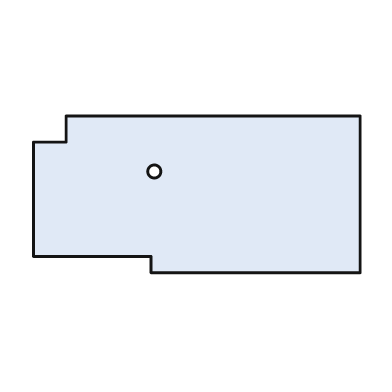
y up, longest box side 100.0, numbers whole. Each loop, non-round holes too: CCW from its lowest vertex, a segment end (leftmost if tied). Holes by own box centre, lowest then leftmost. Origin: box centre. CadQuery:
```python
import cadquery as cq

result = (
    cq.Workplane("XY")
    .moveTo(-14.0, -24.0)
    .lineTo(50.0, -24.0)
    .lineTo(50.0, 24.0)
    .lineTo(-40.0, 24.0)
    .lineTo(-40.0, 16.0)
    .lineTo(-50.0, 16.0)
    .lineTo(-50.0, -19.0)
    .lineTo(-14.0, -19.0)
    .close()
    .moveTo(-13.0, 7.0)
    .circle(2.0)
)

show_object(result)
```